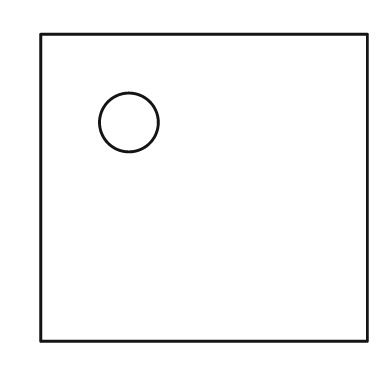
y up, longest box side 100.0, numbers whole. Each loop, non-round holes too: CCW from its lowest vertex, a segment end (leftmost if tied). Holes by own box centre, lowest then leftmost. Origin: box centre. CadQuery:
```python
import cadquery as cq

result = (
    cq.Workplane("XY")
    .moveTo(-50.0, -47.0)
    .lineTo(50.0, -47.0)
    .lineTo(50.0, 47.0)
    .lineTo(-50.0, 47.0)
    .close()
    .moveTo(-23.0, 20.0)
    .circle(9.0)
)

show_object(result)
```